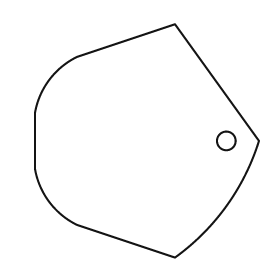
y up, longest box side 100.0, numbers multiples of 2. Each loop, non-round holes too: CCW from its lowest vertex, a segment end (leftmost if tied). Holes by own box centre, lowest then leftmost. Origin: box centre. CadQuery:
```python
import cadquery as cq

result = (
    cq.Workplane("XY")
    .moveTo(12.0, -50.0)
    .threePointArc((34.0, -28.0), (48.0, 0.0))
    .lineTo(12.0, 50.0)
    .lineTo(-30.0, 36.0)
    .threePointArc((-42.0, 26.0), (-48.0, 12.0))
    .lineTo(-48.0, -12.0)
    .threePointArc((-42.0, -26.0), (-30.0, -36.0))
    .close()
    .moveTo(34.0, 0.0)
    .circle(4.0)
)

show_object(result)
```